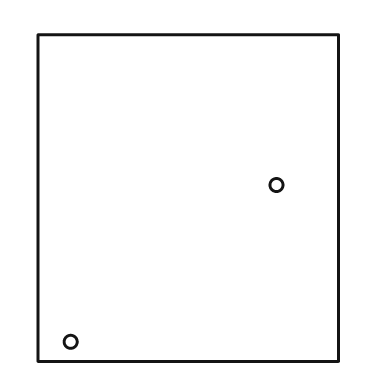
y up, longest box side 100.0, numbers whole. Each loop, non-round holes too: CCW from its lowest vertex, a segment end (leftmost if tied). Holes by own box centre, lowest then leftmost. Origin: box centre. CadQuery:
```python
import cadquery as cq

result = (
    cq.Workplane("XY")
    .moveTo(-46.0, -50.0)
    .lineTo(46.0, -50.0)
    .lineTo(46.0, 50.0)
    .lineTo(-46.0, 50.0)
    .close()
    .moveTo(-36.0, -44.0)
    .circle(2.0)
    .moveTo(27.0, 4.0)
    .circle(2.0)
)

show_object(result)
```